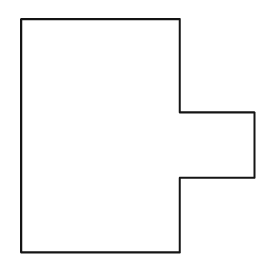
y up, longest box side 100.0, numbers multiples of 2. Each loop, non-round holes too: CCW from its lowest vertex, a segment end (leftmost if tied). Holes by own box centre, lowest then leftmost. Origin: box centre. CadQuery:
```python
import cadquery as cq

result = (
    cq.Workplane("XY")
    .moveTo(-50.0, -50.0)
    .lineTo(18.0, -50.0)
    .lineTo(18.0, -18.0)
    .lineTo(50.0, -18.0)
    .lineTo(50.0, 10.0)
    .lineTo(18.0, 10.0)
    .lineTo(18.0, 50.0)
    .lineTo(-50.0, 50.0)
    .close()
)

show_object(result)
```